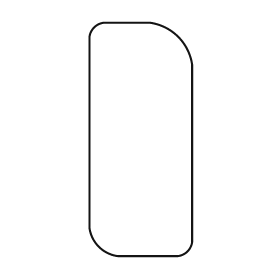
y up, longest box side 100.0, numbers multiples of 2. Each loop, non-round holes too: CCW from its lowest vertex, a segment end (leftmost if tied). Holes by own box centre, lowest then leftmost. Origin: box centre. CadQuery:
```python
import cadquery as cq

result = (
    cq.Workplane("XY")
    .moveTo(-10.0, -50.0)
    .lineTo(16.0, -50.0)
    .threePointArc((20.0, -48.0), (22.0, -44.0))
    .lineTo(22.0, 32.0)
    .threePointArc((16.0, 44.0), (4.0, 50.0))
    .lineTo(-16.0, 50.0)
    .threePointArc((-20.0, 48.0), (-22.0, 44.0))
    .lineTo(-22.0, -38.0)
    .threePointArc((-18.0, -46.0), (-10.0, -50.0))
    .close()
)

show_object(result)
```